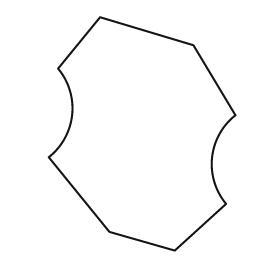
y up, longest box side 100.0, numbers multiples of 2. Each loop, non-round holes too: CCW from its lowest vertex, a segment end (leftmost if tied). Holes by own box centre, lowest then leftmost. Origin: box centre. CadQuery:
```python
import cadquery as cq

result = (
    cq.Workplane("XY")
    .moveTo(14.0, -50.0)
    .lineTo(36.0, -30.0)
    .threePointArc((30.0, -10.0), (40.0, 8.0))
    .lineTo(22.0, 38.0)
    .lineTo(-18.0, 50.0)
    .lineTo(-36.0, 28.0)
    .threePointArc((-30.0, 8.0), (-40.0, -10.0))
    .lineTo(-14.0, -42.0)
    .close()
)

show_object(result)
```